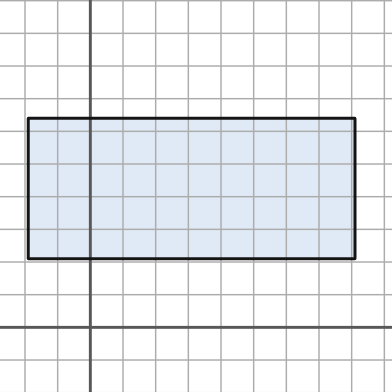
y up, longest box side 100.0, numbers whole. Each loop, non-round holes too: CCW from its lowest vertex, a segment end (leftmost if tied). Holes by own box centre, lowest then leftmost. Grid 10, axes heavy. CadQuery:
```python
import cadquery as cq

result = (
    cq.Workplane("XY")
    .moveTo(-19.0, 21.0)
    .lineTo(81.0, 21.0)
    .lineTo(81.0, 64.0)
    .lineTo(-19.0, 64.0)
    .close()
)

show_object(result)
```